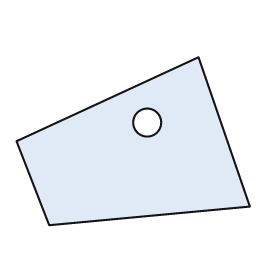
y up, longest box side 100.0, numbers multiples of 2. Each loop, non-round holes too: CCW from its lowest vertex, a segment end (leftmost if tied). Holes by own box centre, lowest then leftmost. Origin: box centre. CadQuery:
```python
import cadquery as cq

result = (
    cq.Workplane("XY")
    .moveTo(-36.0, -36.0)
    .lineTo(50.0, -28.0)
    .lineTo(28.0, 36.0)
    .lineTo(-50.0, 0.0)
    .close()
    .moveTo(6.0, 8.0)
    .circle(6.0)
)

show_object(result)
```